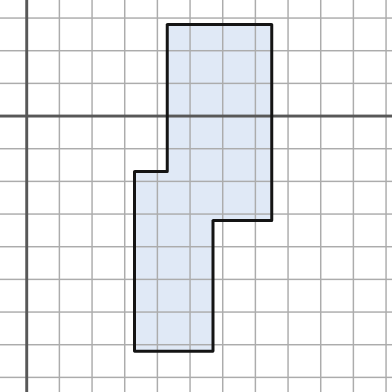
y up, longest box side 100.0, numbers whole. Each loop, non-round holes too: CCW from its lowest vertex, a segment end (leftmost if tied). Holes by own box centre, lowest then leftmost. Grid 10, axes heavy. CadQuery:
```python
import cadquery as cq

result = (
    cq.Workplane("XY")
    .moveTo(33.0, -72.0)
    .lineTo(57.0, -72.0)
    .lineTo(57.0, -32.0)
    .lineTo(75.0, -32.0)
    .lineTo(75.0, 28.0)
    .lineTo(43.0, 28.0)
    .lineTo(43.0, -17.0)
    .lineTo(33.0, -17.0)
    .close()
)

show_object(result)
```